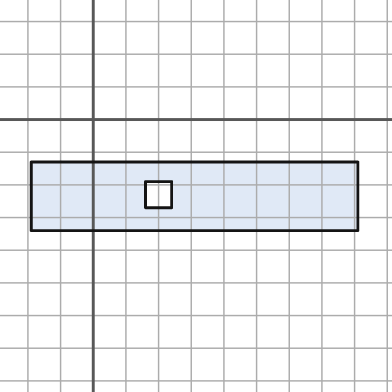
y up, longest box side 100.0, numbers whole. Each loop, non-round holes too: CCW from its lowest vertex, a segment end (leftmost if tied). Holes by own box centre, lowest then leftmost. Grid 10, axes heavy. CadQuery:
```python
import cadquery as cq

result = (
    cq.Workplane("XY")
    .moveTo(-19.0, -34.0)
    .lineTo(81.0, -34.0)
    .lineTo(81.0, -13.0)
    .lineTo(-19.0, -13.0)
    .close()
    .moveTo(16.0, -27.0)
    .lineTo(24.0, -27.0)
    .lineTo(24.0, -19.0)
    .lineTo(16.0, -19.0)
    .close()
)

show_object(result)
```